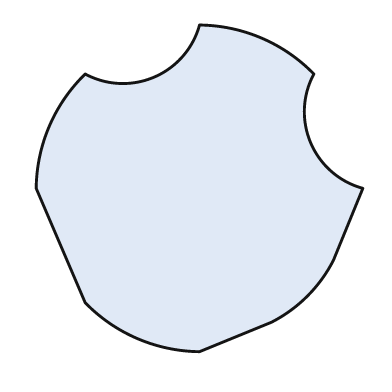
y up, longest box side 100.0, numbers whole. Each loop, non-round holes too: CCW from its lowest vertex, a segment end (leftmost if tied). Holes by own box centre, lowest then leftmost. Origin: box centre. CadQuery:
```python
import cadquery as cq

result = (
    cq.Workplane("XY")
    .moveTo(0.0, -50.0)
    .lineTo(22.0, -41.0)
    .threePointArc((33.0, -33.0), (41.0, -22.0))
    .lineTo(50.0, 0.0)
    .threePointArc((34.0, 14.0), (35.0, 35.0))
    .threePointArc((19.0, 46.0), (0.0, 50.0))
    .threePointArc((-14.0, 34.0), (-35.0, 35.0))
    .threePointArc((-46.0, 19.0), (-50.0, 0.0))
    .lineTo(-35.0, -35.0)
    .threePointArc((-19.0, -46.0), (0.0, -50.0))
    .close()
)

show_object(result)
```